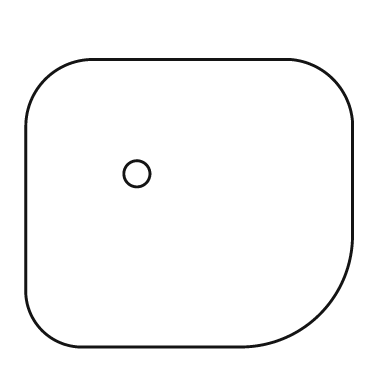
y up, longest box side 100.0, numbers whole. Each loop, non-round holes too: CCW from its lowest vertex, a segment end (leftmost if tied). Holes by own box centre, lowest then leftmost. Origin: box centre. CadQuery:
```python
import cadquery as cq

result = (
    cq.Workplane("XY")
    .moveTo(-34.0, -44.0)
    .lineTo(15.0, -44.0)
    .threePointArc((40.0, -34.0), (50.0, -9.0))
    .lineTo(50.0, 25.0)
    .threePointArc((44.0, 38.0), (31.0, 44.0))
    .lineTo(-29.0, 44.0)
    .threePointArc((-44.0, 38.0), (-50.0, 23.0))
    .lineTo(-50.0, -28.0)
    .threePointArc((-45.0, -39.0), (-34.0, -44.0))
    .close()
    .moveTo(-16.0, 9.0)
    .circle(4.0)
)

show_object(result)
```